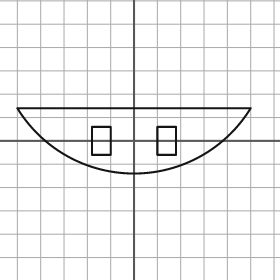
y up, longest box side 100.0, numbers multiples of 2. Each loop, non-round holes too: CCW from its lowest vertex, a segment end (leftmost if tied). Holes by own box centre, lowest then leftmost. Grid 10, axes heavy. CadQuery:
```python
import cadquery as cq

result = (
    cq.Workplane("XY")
    .moveTo(-50.0, 14.0)
    .threePointArc((0.0, -14.0), (50.0, 14.0))
    .close()
    .moveTo(-18.0, -6.0)
    .lineTo(-10.0, -6.0)
    .lineTo(-10.0, 6.0)
    .lineTo(-18.0, 6.0)
    .close()
    .moveTo(10.0, -6.0)
    .lineTo(18.0, -6.0)
    .lineTo(18.0, 6.0)
    .lineTo(10.0, 6.0)
    .close()
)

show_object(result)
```